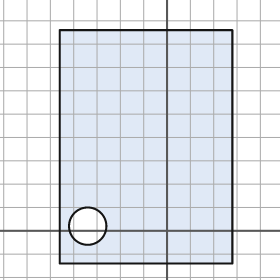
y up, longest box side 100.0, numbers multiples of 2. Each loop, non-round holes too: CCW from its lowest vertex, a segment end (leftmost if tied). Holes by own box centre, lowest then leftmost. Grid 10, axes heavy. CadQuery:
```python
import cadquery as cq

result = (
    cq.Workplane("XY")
    .moveTo(-46.0, -14.0)
    .lineTo(28.0, -14.0)
    .lineTo(28.0, 86.0)
    .lineTo(-46.0, 86.0)
    .close()
    .moveTo(-34.0, 2.0)
    .circle(8.0)
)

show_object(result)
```